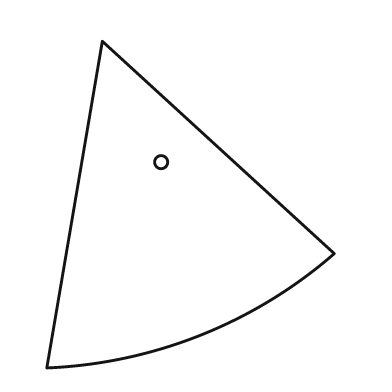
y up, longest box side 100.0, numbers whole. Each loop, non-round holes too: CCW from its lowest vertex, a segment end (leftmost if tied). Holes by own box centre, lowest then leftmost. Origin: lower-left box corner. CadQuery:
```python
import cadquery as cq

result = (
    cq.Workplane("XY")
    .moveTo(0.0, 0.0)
    .threePointArc((47.0, 10.0), (88.0, 35.0))
    .lineTo(17.0, 100.0)
    .close()
    .moveTo(35.0, 63.0)
    .circle(2.0)
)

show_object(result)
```